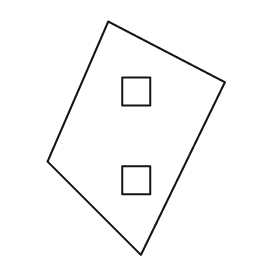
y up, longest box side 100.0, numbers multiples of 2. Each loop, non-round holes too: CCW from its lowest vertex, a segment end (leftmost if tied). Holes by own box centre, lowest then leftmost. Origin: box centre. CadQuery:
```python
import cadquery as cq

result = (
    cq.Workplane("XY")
    .moveTo(2.0, -50.0)
    .lineTo(38.0, 24.0)
    .lineTo(-12.0, 50.0)
    .lineTo(-38.0, -10.0)
    .close()
    .moveTo(-6.0, -24.0)
    .lineTo(6.0, -24.0)
    .lineTo(6.0, -12.0)
    .lineTo(-6.0, -12.0)
    .close()
    .moveTo(-6.0, 14.0)
    .lineTo(6.0, 14.0)
    .lineTo(6.0, 26.0)
    .lineTo(-6.0, 26.0)
    .close()
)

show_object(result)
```